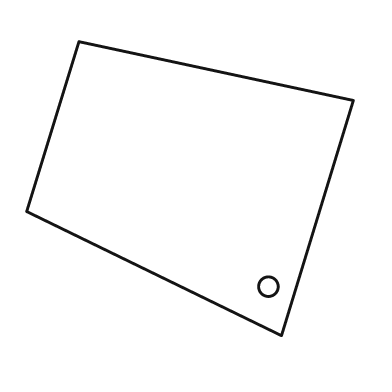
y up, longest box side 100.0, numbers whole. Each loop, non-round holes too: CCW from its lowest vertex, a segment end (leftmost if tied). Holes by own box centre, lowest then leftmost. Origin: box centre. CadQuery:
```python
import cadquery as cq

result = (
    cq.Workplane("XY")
    .moveTo(28.0, -45.0)
    .lineTo(50.0, 27.0)
    .lineTo(-34.0, 45.0)
    .lineTo(-50.0, -7.0)
    .close()
    .moveTo(24.0, -30.0)
    .circle(3.0)
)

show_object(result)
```